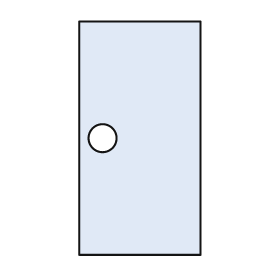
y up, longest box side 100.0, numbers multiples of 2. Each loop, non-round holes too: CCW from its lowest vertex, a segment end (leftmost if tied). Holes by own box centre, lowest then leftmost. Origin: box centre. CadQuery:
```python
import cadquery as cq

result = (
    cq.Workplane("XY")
    .moveTo(-26.0, -50.0)
    .lineTo(26.0, -50.0)
    .lineTo(26.0, 50.0)
    .lineTo(-26.0, 50.0)
    .close()
    .moveTo(-16.0, 0.0)
    .circle(6.0)
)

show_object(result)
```